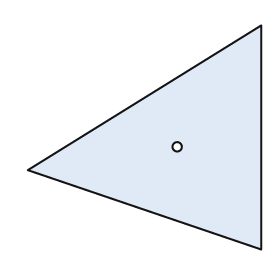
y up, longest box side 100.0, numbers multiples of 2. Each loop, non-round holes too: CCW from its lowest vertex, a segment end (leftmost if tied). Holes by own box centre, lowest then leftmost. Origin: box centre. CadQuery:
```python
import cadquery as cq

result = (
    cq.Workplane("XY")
    .moveTo(50.0, -48.0)
    .lineTo(50.0, 48.0)
    .lineTo(-50.0, -14.0)
    .close()
    .moveTo(14.0, -4.0)
    .circle(2.0)
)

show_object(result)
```